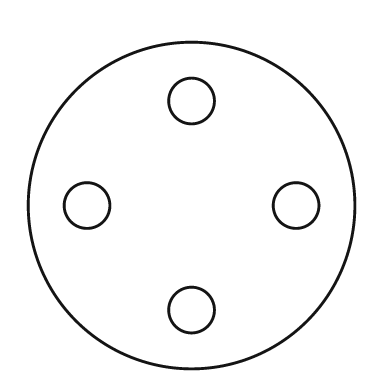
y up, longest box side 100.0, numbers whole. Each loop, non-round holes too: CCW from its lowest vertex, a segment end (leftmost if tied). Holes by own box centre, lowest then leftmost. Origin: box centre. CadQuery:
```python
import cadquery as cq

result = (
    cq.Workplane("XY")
    .moveTo(0.0, 0.0)
    .circle(50.0)
    .moveTo(0.0, -32.0)
    .circle(7.0)
    .moveTo(-32.0, 0.0)
    .circle(7.0)
    .moveTo(32.0, 0.0)
    .circle(7.0)
    .moveTo(0.0, 32.0)
    .circle(7.0)
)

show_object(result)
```